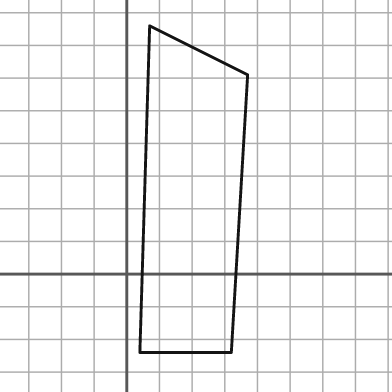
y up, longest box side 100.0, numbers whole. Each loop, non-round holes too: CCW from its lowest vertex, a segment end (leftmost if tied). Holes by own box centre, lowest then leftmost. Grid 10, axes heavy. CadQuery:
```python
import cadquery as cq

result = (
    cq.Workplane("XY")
    .moveTo(4.0, -24.0)
    .lineTo(32.0, -24.0)
    .lineTo(37.0, 61.0)
    .lineTo(7.0, 76.0)
    .close()
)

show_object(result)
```